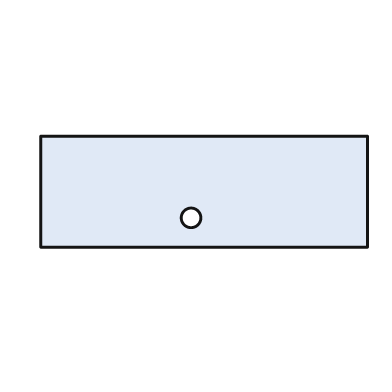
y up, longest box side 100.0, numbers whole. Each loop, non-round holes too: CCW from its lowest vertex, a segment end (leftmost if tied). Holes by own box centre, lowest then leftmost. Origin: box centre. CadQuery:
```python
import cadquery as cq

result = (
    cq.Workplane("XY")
    .moveTo(-50.0, -17.0)
    .lineTo(50.0, -17.0)
    .lineTo(50.0, 17.0)
    .lineTo(-50.0, 17.0)
    .close()
    .moveTo(-4.0, -8.0)
    .circle(3.0)
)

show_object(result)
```